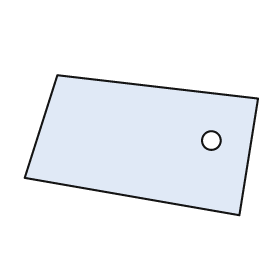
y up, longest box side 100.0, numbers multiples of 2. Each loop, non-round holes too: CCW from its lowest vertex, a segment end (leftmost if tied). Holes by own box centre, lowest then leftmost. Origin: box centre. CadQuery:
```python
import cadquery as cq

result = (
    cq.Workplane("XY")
    .moveTo(42.0, -30.0)
    .lineTo(50.0, 20.0)
    .lineTo(-36.0, 30.0)
    .lineTo(-50.0, -14.0)
    .close()
    .moveTo(30.0, 2.0)
    .circle(4.0)
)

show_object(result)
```